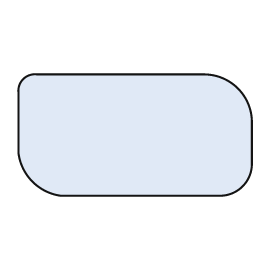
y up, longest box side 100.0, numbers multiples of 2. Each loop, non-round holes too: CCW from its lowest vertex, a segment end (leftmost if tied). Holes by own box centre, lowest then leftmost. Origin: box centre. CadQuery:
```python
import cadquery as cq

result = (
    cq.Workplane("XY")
    .moveTo(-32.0, -26.0)
    .lineTo(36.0, -26.0)
    .threePointArc((46.0, -22.0), (50.0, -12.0))
    .lineTo(50.0, 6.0)
    .threePointArc((44.0, 20.0), (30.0, 26.0))
    .lineTo(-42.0, 26.0)
    .threePointArc((-48.0, 24.0), (-50.0, 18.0))
    .lineTo(-50.0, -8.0)
    .threePointArc((-44.0, -20.0), (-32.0, -26.0))
    .close()
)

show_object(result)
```